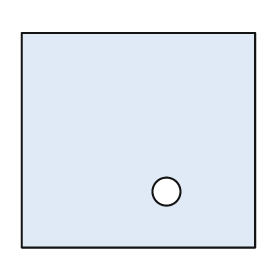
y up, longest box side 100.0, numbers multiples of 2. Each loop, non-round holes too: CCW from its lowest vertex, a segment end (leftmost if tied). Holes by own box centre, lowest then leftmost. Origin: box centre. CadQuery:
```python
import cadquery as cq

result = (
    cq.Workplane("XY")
    .moveTo(-50.0, -46.0)
    .lineTo(50.0, -46.0)
    .lineTo(50.0, 46.0)
    .lineTo(-50.0, 46.0)
    .close()
    .moveTo(12.0, -22.0)
    .circle(6.0)
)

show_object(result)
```